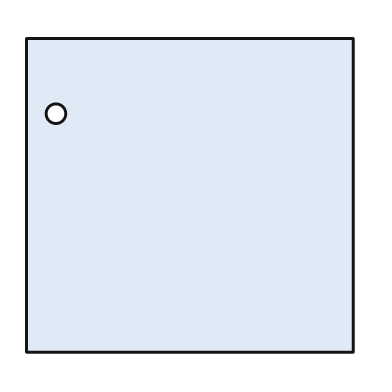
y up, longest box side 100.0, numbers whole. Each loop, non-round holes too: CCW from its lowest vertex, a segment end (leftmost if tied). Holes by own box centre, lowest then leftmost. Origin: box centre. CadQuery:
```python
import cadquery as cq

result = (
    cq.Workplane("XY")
    .moveTo(-50.0, -48.0)
    .lineTo(50.0, -48.0)
    .lineTo(50.0, 48.0)
    .lineTo(-50.0, 48.0)
    .close()
    .moveTo(-41.0, 25.0)
    .circle(3.0)
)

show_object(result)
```